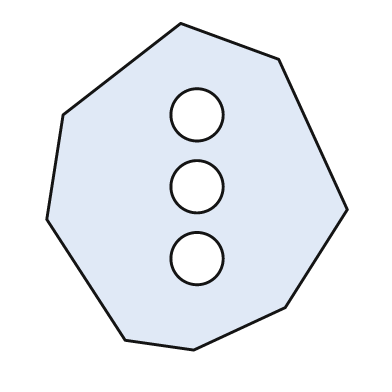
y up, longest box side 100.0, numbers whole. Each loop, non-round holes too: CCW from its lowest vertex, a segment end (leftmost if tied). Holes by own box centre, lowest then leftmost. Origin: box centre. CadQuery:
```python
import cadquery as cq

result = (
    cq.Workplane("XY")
    .moveTo(-1.0, -50.0)
    .lineTo(27.0, -37.0)
    .lineTo(46.0, -7.0)
    .lineTo(25.0, 39.0)
    .lineTo(-5.0, 50.0)
    .lineTo(-41.0, 22.0)
    .lineTo(-46.0, -10.0)
    .lineTo(-22.0, -47.0)
    .close()
    .moveTo(0.0, -22.0)
    .circle(8.0)
    .moveTo(0.0, 0.0)
    .circle(8.0)
    .moveTo(0.0, 22.0)
    .circle(8.0)
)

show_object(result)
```